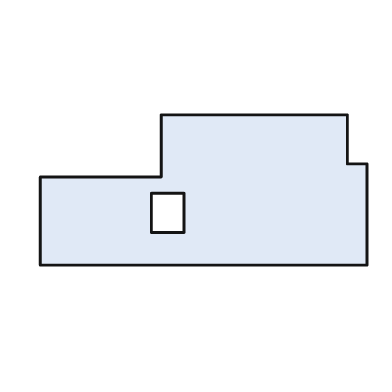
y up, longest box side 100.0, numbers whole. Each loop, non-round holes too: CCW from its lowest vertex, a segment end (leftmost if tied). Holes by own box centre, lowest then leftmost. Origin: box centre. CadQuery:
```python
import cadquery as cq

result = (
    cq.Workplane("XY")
    .moveTo(-50.0, -23.0)
    .lineTo(50.0, -23.0)
    .lineTo(50.0, 8.0)
    .lineTo(44.0, 8.0)
    .lineTo(44.0, 23.0)
    .lineTo(-13.0, 23.0)
    .lineTo(-13.0, 4.0)
    .lineTo(-50.0, 4.0)
    .close()
    .moveTo(-16.0, -13.0)
    .lineTo(-6.0, -13.0)
    .lineTo(-6.0, -1.0)
    .lineTo(-16.0, -1.0)
    .close()
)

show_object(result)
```